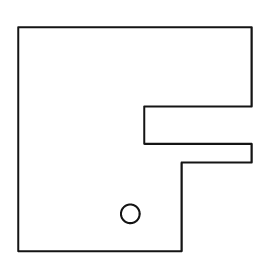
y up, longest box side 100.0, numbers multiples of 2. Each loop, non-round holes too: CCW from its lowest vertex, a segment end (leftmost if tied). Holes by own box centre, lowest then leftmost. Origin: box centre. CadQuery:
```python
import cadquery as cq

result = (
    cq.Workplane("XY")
    .moveTo(-50.0, -48.0)
    .lineTo(20.0, -48.0)
    .lineTo(20.0, -10.0)
    .lineTo(50.0, -10.0)
    .lineTo(50.0, -2.0)
    .lineTo(4.0, -2.0)
    .lineTo(4.0, 14.0)
    .lineTo(50.0, 14.0)
    .lineTo(50.0, 48.0)
    .lineTo(-50.0, 48.0)
    .close()
    .moveTo(-2.0, -32.0)
    .circle(4.0)
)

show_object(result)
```